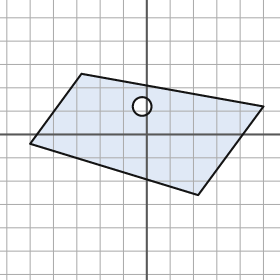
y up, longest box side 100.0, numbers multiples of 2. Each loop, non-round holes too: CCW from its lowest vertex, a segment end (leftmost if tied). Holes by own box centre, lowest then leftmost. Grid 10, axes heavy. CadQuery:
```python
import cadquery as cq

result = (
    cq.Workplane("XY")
    .moveTo(22.0, -26.0)
    .lineTo(50.0, 12.0)
    .lineTo(-28.0, 26.0)
    .lineTo(-50.0, -4.0)
    .close()
    .moveTo(-2.0, 12.0)
    .circle(4.0)
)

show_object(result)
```